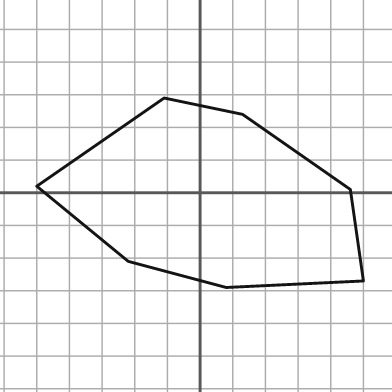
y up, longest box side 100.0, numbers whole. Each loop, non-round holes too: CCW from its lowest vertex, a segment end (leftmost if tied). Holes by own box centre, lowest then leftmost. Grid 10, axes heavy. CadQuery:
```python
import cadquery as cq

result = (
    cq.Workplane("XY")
    .moveTo(8.0, -29.0)
    .lineTo(50.0, -27.0)
    .lineTo(46.0, 1.0)
    .lineTo(13.0, 24.0)
    .lineTo(-11.0, 29.0)
    .lineTo(-50.0, 2.0)
    .lineTo(-22.0, -21.0)
    .close()
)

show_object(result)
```